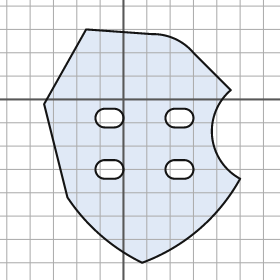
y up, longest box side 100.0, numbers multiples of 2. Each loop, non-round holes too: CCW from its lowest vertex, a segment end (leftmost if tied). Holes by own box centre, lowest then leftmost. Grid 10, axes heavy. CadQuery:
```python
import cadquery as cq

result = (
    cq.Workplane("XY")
    .moveTo(8.0, -70.0)
    .threePointArc((32.0, -56.0), (50.0, -34.0))
    .threePointArc((38.0, -16.0), (46.0, 4.0))
    .lineTo(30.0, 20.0)
    .threePointArc((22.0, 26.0), (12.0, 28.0))
    .lineTo(-16.0, 30.0)
    .lineTo(-34.0, -2.0)
    .lineTo(-24.0, -42.0)
    .threePointArc((-10.0, -58.0), (8.0, -70.0))
    .close()
    .moveTo(-8.0, -34.0)
    .lineTo(-4.0, -34.0)
    .threePointArc((0.0, -30.0), (-4.0, -26.0))
    .lineTo(-8.0, -26.0)
    .threePointArc((-12.0, -30.0), (-8.0, -34.0))
    .close()
    .moveTo(22.0, -34.0)
    .lineTo(26.0, -34.0)
    .threePointArc((30.0, -30.0), (26.0, -26.0))
    .lineTo(22.0, -26.0)
    .threePointArc((18.0, -30.0), (22.0, -34.0))
    .close()
    .moveTo(-8.0, -12.0)
    .lineTo(-4.0, -12.0)
    .threePointArc((0.0, -8.0), (-4.0, -4.0))
    .lineTo(-8.0, -4.0)
    .threePointArc((-12.0, -8.0), (-8.0, -12.0))
    .close()
    .moveTo(22.0, -12.0)
    .lineTo(26.0, -12.0)
    .threePointArc((30.0, -8.0), (26.0, -4.0))
    .lineTo(22.0, -4.0)
    .threePointArc((18.0, -8.0), (22.0, -12.0))
    .close()
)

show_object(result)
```